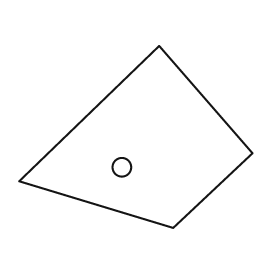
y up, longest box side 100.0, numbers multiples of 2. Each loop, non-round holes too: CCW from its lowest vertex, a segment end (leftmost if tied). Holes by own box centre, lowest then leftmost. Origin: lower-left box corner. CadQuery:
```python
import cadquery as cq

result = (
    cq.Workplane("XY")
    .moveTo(66.0, 0.0)
    .lineTo(100.0, 32.0)
    .lineTo(60.0, 78.0)
    .lineTo(0.0, 20.0)
    .close()
    .moveTo(44.0, 26.0)
    .circle(4.0)
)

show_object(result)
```